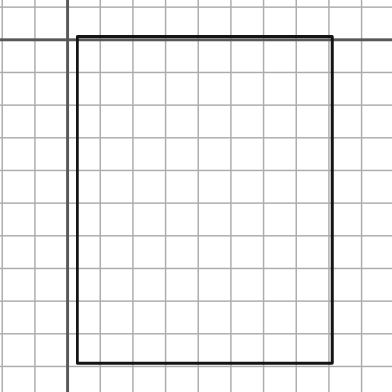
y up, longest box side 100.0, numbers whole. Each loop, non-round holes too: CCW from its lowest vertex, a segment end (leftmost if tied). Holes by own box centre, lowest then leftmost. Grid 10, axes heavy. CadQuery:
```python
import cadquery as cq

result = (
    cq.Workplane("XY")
    .moveTo(3.0, -99.0)
    .lineTo(81.0, -99.0)
    .lineTo(81.0, 1.0)
    .lineTo(3.0, 1.0)
    .close()
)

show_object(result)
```